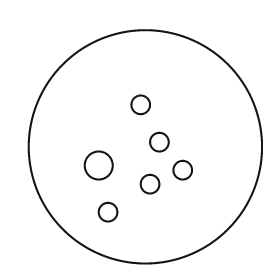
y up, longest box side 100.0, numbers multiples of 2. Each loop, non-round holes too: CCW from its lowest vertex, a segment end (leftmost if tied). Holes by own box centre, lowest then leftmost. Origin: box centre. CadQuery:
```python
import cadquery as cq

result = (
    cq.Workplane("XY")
    .moveTo(0.0, 0.0)
    .circle(50.0)
    .moveTo(-16.0, -28.0)
    .circle(4.0)
    .moveTo(2.0, -16.0)
    .circle(4.0)
    .moveTo(16.0, -10.0)
    .circle(4.0)
    .moveTo(-20.0, -8.0)
    .circle(6.0)
    .moveTo(6.0, 2.0)
    .circle(4.0)
    .moveTo(-2.0, 18.0)
    .circle(4.0)
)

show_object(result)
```